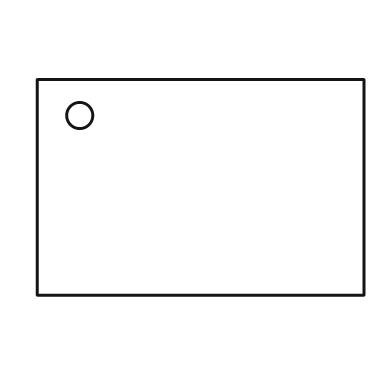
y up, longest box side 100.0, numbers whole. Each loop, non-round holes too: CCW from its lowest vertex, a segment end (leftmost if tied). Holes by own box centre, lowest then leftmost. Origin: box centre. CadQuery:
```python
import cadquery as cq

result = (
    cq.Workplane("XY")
    .moveTo(-50.0, -33.0)
    .lineTo(50.0, -33.0)
    .lineTo(50.0, 33.0)
    .lineTo(-50.0, 33.0)
    .close()
    .moveTo(-37.0, 22.0)
    .circle(4.0)
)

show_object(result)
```